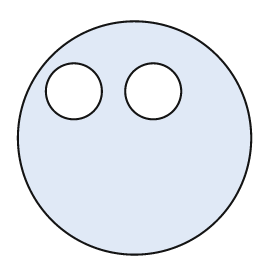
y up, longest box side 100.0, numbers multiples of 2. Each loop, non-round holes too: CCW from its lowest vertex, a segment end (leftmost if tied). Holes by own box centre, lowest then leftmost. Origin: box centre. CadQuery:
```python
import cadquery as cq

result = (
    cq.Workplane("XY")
    .moveTo(0.0, 0.0)
    .circle(50.0)
    .moveTo(-26.0, 20.0)
    .circle(12.0)
    .moveTo(8.0, 20.0)
    .circle(12.0)
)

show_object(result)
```